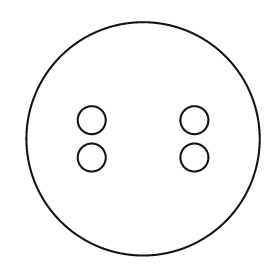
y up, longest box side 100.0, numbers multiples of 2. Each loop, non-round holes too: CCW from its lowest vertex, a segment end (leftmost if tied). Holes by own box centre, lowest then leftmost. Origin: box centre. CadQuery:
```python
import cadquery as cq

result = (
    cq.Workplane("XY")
    .moveTo(0.0, 0.0)
    .circle(50.0)
    .moveTo(-22.0, -8.0)
    .circle(6.0)
    .moveTo(22.0, -8.0)
    .circle(6.0)
    .moveTo(-22.0, 8.0)
    .circle(6.0)
    .moveTo(22.0, 8.0)
    .circle(6.0)
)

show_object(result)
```